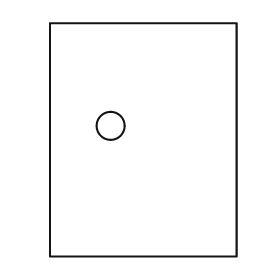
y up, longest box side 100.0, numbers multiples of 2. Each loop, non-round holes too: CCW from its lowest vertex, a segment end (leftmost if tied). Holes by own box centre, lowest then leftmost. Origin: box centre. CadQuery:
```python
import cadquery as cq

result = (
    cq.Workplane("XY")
    .moveTo(-40.0, -50.0)
    .lineTo(40.0, -50.0)
    .lineTo(40.0, 50.0)
    .lineTo(-40.0, 50.0)
    .close()
    .moveTo(-14.0, 6.0)
    .circle(6.0)
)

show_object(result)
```